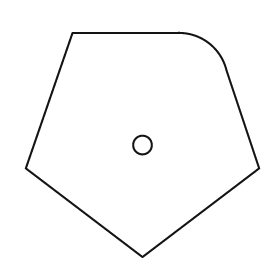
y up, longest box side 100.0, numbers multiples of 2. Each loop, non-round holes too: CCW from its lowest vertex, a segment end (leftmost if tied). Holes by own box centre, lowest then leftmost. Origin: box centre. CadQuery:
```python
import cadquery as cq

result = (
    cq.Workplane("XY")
    .moveTo(0.0, -48.0)
    .lineTo(50.0, -10.0)
    .lineTo(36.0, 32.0)
    .threePointArc((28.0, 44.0), (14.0, 48.0))
    .lineTo(-30.0, 48.0)
    .lineTo(-50.0, -10.0)
    .close()
    .moveTo(0.0, 0.0)
    .circle(4.0)
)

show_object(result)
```